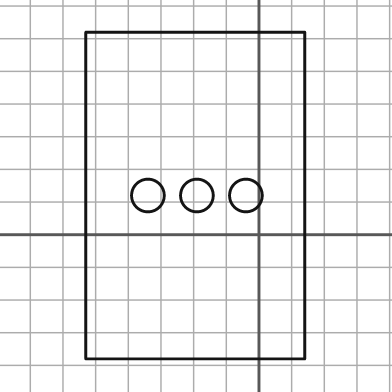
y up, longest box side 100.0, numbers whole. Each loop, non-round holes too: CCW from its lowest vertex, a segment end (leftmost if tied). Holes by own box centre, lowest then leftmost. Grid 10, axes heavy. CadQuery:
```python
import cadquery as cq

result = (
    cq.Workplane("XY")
    .moveTo(-53.0, -38.0)
    .lineTo(14.0, -38.0)
    .lineTo(14.0, 62.0)
    .lineTo(-53.0, 62.0)
    .close()
    .moveTo(-34.0, 12.0)
    .circle(5.0)
    .moveTo(-19.0, 12.0)
    .circle(5.0)
    .moveTo(-4.0, 12.0)
    .circle(5.0)
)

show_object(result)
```